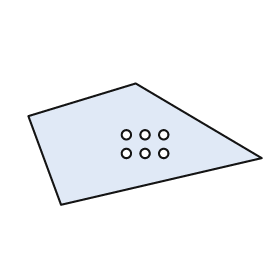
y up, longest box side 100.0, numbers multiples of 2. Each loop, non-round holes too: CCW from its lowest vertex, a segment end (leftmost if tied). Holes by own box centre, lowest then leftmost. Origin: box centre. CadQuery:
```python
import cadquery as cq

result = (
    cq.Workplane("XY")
    .moveTo(-36.0, -26.0)
    .lineTo(50.0, -6.0)
    .lineTo(-4.0, 26.0)
    .lineTo(-50.0, 12.0)
    .close()
    .moveTo(-8.0, -4.0)
    .circle(2.0)
    .moveTo(0.0, -4.0)
    .circle(2.0)
    .moveTo(8.0, -4.0)
    .circle(2.0)
    .moveTo(-8.0, 4.0)
    .circle(2.0)
    .moveTo(0.0, 4.0)
    .circle(2.0)
    .moveTo(8.0, 4.0)
    .circle(2.0)
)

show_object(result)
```